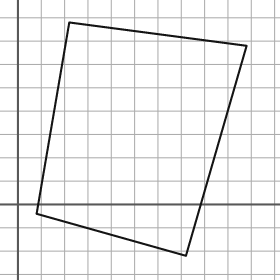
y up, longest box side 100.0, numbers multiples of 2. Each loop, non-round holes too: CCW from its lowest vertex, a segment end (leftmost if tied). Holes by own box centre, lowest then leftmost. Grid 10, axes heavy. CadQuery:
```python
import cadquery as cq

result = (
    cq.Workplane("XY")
    .moveTo(72.0, -22.0)
    .lineTo(98.0, 68.0)
    .lineTo(22.0, 78.0)
    .lineTo(8.0, -4.0)
    .close()
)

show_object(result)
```